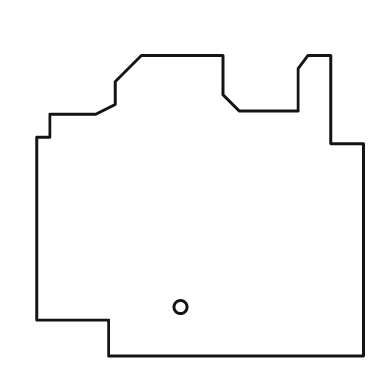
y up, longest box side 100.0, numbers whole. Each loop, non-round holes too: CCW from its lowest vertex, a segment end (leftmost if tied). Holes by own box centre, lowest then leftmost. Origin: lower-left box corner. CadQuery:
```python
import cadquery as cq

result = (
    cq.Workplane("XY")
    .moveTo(22.0, 0.0)
    .lineTo(100.0, 0.0)
    .lineTo(100.0, 65.0)
    .lineTo(90.0, 65.0)
    .lineTo(90.0, 92.0)
    .lineTo(83.0, 92.0)
    .lineTo(80.0, 88.0)
    .lineTo(80.0, 75.0)
    .lineTo(62.0, 75.0)
    .lineTo(57.0, 80.0)
    .lineTo(57.0, 92.0)
    .lineTo(32.0, 92.0)
    .lineTo(24.0, 84.0)
    .lineTo(24.0, 77.0)
    .lineTo(18.0, 74.0)
    .lineTo(4.0, 74.0)
    .lineTo(4.0, 67.0)
    .lineTo(0.0, 67.0)
    .lineTo(0.0, 11.0)
    .lineTo(22.0, 11.0)
    .close()
    .moveTo(44.0, 15.0)
    .circle(2.0)
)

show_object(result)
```